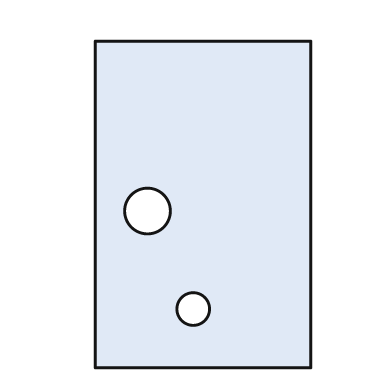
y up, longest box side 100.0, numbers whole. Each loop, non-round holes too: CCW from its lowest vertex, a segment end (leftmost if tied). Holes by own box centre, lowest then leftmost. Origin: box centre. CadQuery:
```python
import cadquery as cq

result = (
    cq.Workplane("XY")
    .moveTo(-33.0, -50.0)
    .lineTo(33.0, -50.0)
    .lineTo(33.0, 50.0)
    .lineTo(-33.0, 50.0)
    .close()
    .moveTo(-3.0, -32.0)
    .circle(5.0)
    .moveTo(-17.0, -2.0)
    .circle(7.0)
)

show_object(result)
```